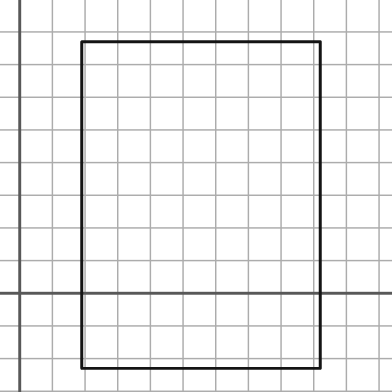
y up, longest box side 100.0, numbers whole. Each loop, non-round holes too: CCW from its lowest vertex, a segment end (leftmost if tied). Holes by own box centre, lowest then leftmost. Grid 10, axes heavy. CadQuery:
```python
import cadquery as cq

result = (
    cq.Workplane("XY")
    .moveTo(19.0, -23.0)
    .lineTo(92.0, -23.0)
    .lineTo(92.0, 77.0)
    .lineTo(19.0, 77.0)
    .close()
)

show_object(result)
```